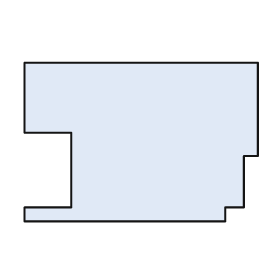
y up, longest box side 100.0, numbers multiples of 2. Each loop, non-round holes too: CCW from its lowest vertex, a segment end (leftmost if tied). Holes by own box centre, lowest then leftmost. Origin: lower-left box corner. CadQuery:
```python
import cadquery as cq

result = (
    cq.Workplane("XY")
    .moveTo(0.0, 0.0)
    .lineTo(86.0, 0.0)
    .lineTo(86.0, 6.0)
    .lineTo(94.0, 6.0)
    .lineTo(94.0, 28.0)
    .lineTo(100.0, 28.0)
    .lineTo(100.0, 68.0)
    .lineTo(0.0, 68.0)
    .lineTo(0.0, 38.0)
    .lineTo(20.0, 38.0)
    .lineTo(20.0, 6.0)
    .lineTo(0.0, 6.0)
    .close()
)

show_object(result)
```